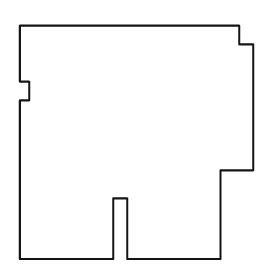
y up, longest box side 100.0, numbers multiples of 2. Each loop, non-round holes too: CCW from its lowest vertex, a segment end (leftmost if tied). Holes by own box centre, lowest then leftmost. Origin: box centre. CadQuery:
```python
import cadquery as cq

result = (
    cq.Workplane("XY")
    .moveTo(-50.0, -50.0)
    .lineTo(-10.0, -50.0)
    .lineTo(-10.0, -24.0)
    .lineTo(-4.0, -24.0)
    .lineTo(-4.0, -50.0)
    .lineTo(36.0, -50.0)
    .lineTo(36.0, -12.0)
    .lineTo(50.0, -12.0)
    .lineTo(50.0, 42.0)
    .lineTo(44.0, 42.0)
    .lineTo(44.0, 50.0)
    .lineTo(-50.0, 50.0)
    .lineTo(-50.0, 26.0)
    .lineTo(-46.0, 26.0)
    .lineTo(-46.0, 18.0)
    .lineTo(-50.0, 18.0)
    .close()
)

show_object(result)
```